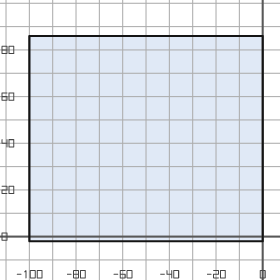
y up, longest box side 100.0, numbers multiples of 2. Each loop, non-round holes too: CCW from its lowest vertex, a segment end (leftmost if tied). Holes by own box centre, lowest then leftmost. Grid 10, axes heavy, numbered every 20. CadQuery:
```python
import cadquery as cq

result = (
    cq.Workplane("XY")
    .moveTo(-100.0, -2.0)
    .lineTo(0.0, -2.0)
    .lineTo(0.0, 86.0)
    .lineTo(-100.0, 86.0)
    .close()
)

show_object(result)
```